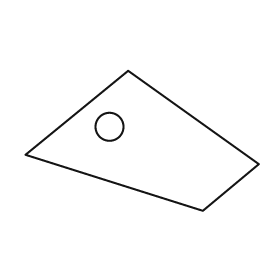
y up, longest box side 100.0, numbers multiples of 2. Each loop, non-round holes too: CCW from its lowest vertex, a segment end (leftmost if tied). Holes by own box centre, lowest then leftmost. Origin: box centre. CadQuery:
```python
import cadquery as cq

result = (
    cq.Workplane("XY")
    .moveTo(26.0, -30.0)
    .lineTo(50.0, -10.0)
    .lineTo(-6.0, 30.0)
    .lineTo(-50.0, -6.0)
    .close()
    .moveTo(-14.0, 6.0)
    .circle(6.0)
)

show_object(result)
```